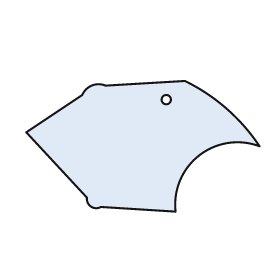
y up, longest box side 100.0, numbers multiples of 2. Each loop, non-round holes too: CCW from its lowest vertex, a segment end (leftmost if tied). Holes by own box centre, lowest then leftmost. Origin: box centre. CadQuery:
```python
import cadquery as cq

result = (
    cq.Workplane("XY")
    .moveTo(14.0, -28.0)
    .threePointArc((24.0, -4.0), (50.0, 0.0))
    .threePointArc((36.0, 16.0), (18.0, 28.0))
    .lineTo(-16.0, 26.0)
    .threePointArc((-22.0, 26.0), (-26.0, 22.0))
    .lineTo(-50.0, 6.0)
    .lineTo(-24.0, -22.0)
    .threePointArc((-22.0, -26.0), (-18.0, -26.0))
    .close()
    .moveTo(10.0, 20.0)
    .circle(2.0)
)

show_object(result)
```